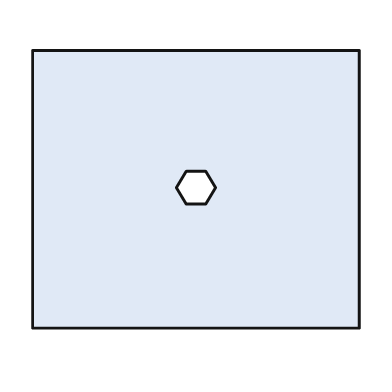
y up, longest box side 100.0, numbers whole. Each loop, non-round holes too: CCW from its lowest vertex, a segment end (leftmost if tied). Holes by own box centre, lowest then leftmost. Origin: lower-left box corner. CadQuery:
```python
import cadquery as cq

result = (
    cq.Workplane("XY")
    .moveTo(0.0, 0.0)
    .lineTo(100.0, 0.0)
    .lineTo(100.0, 85.0)
    .lineTo(0.0, 85.0)
    .close()
    .moveTo(47.0, 38.0)
    .lineTo(53.0, 38.0)
    .lineTo(56.0, 43.0)
    .lineTo(53.0, 48.0)
    .lineTo(47.0, 48.0)
    .lineTo(44.0, 43.0)
    .close()
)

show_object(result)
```